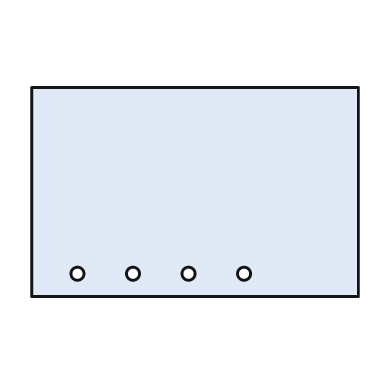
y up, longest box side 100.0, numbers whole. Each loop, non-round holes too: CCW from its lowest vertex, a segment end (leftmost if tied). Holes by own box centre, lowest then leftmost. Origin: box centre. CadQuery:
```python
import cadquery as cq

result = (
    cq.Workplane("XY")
    .moveTo(-50.0, -32.0)
    .lineTo(50.0, -32.0)
    .lineTo(50.0, 32.0)
    .lineTo(-50.0, 32.0)
    .close()
    .moveTo(-36.0, -25.0)
    .circle(2.0)
    .moveTo(-19.0, -25.0)
    .circle(2.0)
    .moveTo(-2.0, -25.0)
    .circle(2.0)
    .moveTo(15.0, -25.0)
    .circle(2.0)
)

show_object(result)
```